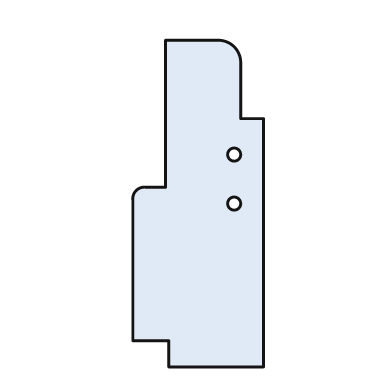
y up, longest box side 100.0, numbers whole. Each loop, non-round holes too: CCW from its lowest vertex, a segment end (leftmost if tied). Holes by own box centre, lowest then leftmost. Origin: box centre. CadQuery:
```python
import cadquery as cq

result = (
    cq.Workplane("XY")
    .moveTo(-9.0, -50.0)
    .lineTo(20.0, -50.0)
    .lineTo(20.0, 26.0)
    .lineTo(13.0, 26.0)
    .lineTo(13.0, 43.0)
    .threePointArc((11.0, 48.0), (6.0, 50.0))
    .lineTo(-10.0, 50.0)
    .lineTo(-10.0, 5.0)
    .lineTo(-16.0, 5.0)
    .threePointArc((-19.0, 4.0), (-20.0, 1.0))
    .lineTo(-20.0, -42.0)
    .lineTo(-9.0, -42.0)
    .close()
    .moveTo(11.0, 0.0)
    .circle(2.0)
    .moveTo(11.0, 15.0)
    .circle(2.0)
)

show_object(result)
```